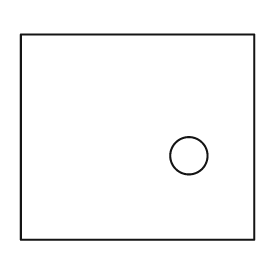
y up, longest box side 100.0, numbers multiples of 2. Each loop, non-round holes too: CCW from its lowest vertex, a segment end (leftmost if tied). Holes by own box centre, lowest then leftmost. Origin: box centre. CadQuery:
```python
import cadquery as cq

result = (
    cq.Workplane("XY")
    .moveTo(-50.0, -44.0)
    .lineTo(50.0, -44.0)
    .lineTo(50.0, 44.0)
    .lineTo(-50.0, 44.0)
    .close()
    .moveTo(22.0, -8.0)
    .circle(8.0)
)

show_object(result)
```